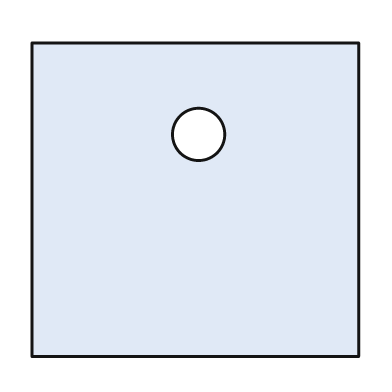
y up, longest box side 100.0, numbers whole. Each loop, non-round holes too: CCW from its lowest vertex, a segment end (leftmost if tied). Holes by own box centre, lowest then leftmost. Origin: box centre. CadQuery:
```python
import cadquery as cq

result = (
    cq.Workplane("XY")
    .moveTo(-50.0, -48.0)
    .lineTo(50.0, -48.0)
    .lineTo(50.0, 48.0)
    .lineTo(-50.0, 48.0)
    .close()
    .moveTo(1.0, 20.0)
    .circle(8.0)
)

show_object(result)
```